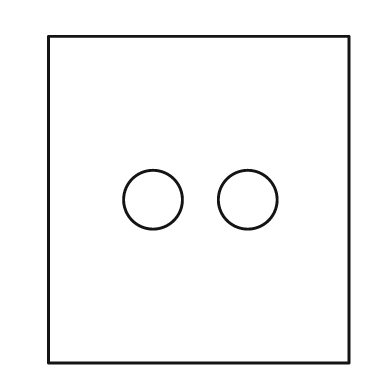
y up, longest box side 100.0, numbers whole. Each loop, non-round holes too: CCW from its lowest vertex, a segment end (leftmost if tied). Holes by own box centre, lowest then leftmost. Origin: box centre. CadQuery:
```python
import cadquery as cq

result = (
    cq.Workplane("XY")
    .moveTo(-46.0, -50.0)
    .lineTo(46.0, -50.0)
    .lineTo(46.0, 50.0)
    .lineTo(-46.0, 50.0)
    .close()
    .moveTo(-14.0, 0.0)
    .circle(9.0)
    .moveTo(15.0, 0.0)
    .circle(9.0)
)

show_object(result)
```